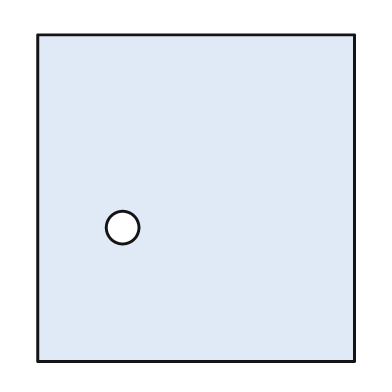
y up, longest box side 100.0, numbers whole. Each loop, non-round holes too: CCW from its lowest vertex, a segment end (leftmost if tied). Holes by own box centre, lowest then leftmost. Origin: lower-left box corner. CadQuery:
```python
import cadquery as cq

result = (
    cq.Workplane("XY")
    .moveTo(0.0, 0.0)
    .lineTo(97.0, 0.0)
    .lineTo(97.0, 100.0)
    .lineTo(0.0, 100.0)
    .close()
    .moveTo(26.0, 41.0)
    .circle(5.0)
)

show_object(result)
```